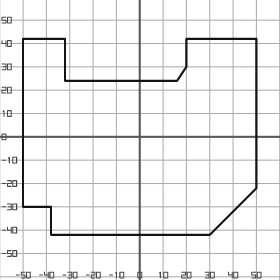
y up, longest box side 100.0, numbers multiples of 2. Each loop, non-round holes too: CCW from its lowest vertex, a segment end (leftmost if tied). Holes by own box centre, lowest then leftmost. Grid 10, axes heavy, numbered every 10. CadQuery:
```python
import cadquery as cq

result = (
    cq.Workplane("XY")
    .moveTo(-38.0, -42.0)
    .lineTo(30.0, -42.0)
    .lineTo(50.0, -22.0)
    .lineTo(50.0, 42.0)
    .lineTo(20.0, 42.0)
    .lineTo(20.0, 30.0)
    .lineTo(16.0, 24.0)
    .lineTo(-32.0, 24.0)
    .lineTo(-32.0, 42.0)
    .lineTo(-50.0, 42.0)
    .lineTo(-50.0, -30.0)
    .lineTo(-38.0, -30.0)
    .close()
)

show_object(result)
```